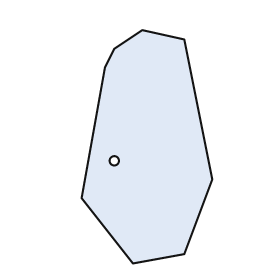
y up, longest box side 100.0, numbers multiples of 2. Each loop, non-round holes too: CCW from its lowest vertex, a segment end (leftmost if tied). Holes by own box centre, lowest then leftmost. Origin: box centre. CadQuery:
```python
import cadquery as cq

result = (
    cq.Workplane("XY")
    .moveTo(-6.0, -50.0)
    .lineTo(16.0, -46.0)
    .lineTo(28.0, -14.0)
    .lineTo(16.0, 46.0)
    .lineTo(-2.0, 50.0)
    .lineTo(-14.0, 42.0)
    .lineTo(-18.0, 34.0)
    .lineTo(-28.0, -22.0)
    .close()
    .moveTo(-14.0, -6.0)
    .circle(2.0)
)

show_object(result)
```